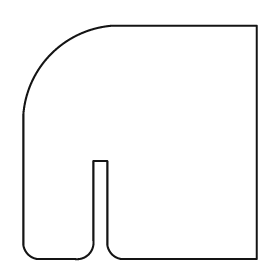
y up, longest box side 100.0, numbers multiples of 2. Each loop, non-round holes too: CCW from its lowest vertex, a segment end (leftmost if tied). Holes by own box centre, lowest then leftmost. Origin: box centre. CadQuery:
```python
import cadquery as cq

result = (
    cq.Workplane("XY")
    .moveTo(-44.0, -50.0)
    .lineTo(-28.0, -50.0)
    .threePointArc((-22.0, -48.0), (-20.0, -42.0))
    .lineTo(-20.0, -8.0)
    .lineTo(-14.0, -8.0)
    .lineTo(-14.0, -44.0)
    .threePointArc((-12.0, -48.0), (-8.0, -50.0))
    .lineTo(50.0, -50.0)
    .lineTo(50.0, 50.0)
    .lineTo(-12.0, 50.0)
    .threePointArc((-38.0, 38.0), (-50.0, 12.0))
    .lineTo(-50.0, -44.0)
    .threePointArc((-48.0, -48.0), (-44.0, -50.0))
    .close()
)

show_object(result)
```